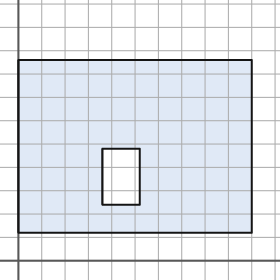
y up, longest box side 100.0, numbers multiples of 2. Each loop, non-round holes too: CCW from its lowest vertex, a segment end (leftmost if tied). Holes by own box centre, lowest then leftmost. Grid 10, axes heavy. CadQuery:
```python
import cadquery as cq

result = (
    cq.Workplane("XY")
    .moveTo(0.0, 12.0)
    .lineTo(100.0, 12.0)
    .lineTo(100.0, 86.0)
    .lineTo(0.0, 86.0)
    .close()
    .moveTo(36.0, 24.0)
    .lineTo(52.0, 24.0)
    .lineTo(52.0, 48.0)
    .lineTo(36.0, 48.0)
    .close()
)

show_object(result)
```